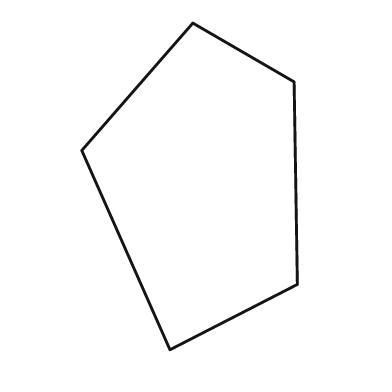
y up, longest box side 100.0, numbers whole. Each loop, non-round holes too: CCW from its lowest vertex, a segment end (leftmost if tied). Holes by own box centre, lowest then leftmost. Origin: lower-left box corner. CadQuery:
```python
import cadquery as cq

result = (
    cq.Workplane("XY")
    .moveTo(27.0, 0.0)
    .lineTo(66.0, 20.0)
    .lineTo(65.0, 82.0)
    .lineTo(34.0, 100.0)
    .lineTo(0.0, 61.0)
    .close()
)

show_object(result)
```